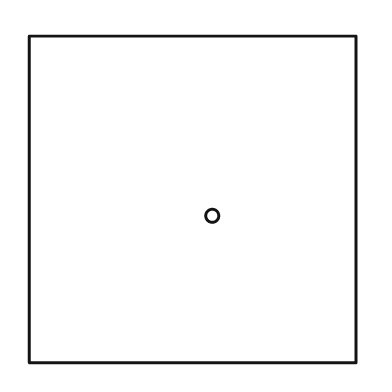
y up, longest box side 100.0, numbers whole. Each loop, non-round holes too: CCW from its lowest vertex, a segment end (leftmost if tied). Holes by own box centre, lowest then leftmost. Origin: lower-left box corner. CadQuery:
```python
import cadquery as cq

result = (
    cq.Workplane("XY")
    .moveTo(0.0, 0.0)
    .lineTo(100.0, 0.0)
    .lineTo(100.0, 100.0)
    .lineTo(0.0, 100.0)
    .close()
    .moveTo(56.0, 45.0)
    .circle(2.0)
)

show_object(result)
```